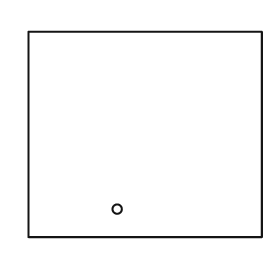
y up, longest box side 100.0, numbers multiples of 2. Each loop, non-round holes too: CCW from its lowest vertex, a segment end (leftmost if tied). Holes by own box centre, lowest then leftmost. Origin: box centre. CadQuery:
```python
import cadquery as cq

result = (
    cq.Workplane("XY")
    .moveTo(-50.0, -44.0)
    .lineTo(50.0, -44.0)
    .lineTo(50.0, 44.0)
    .lineTo(-50.0, 44.0)
    .close()
    .moveTo(-12.0, -32.0)
    .circle(2.0)
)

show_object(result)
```